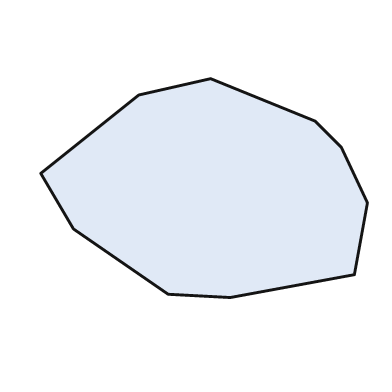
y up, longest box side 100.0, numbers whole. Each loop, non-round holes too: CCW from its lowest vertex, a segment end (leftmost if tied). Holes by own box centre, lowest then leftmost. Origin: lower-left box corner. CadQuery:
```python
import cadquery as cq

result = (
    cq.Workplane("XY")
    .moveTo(58.0, 0.0)
    .lineTo(96.0, 7.0)
    .lineTo(100.0, 29.0)
    .lineTo(92.0, 46.0)
    .lineTo(84.0, 54.0)
    .lineTo(52.0, 67.0)
    .lineTo(30.0, 62.0)
    .lineTo(0.0, 38.0)
    .lineTo(10.0, 21.0)
    .lineTo(39.0, 1.0)
    .close()
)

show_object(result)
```